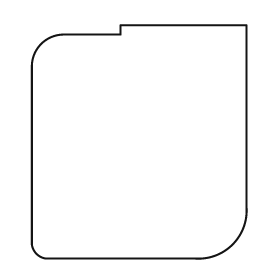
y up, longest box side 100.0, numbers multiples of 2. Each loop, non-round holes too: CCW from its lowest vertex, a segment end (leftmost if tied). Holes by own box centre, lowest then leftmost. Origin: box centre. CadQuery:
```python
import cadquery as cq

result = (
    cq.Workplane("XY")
    .moveTo(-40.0, -50.0)
    .lineTo(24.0, -50.0)
    .threePointArc((40.0, -44.0), (46.0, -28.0))
    .lineTo(46.0, 50.0)
    .lineTo(-8.0, 50.0)
    .lineTo(-8.0, 46.0)
    .lineTo(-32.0, 46.0)
    .threePointArc((-42.0, 42.0), (-46.0, 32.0))
    .lineTo(-46.0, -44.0)
    .threePointArc((-44.0, -48.0), (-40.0, -50.0))
    .close()
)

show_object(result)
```